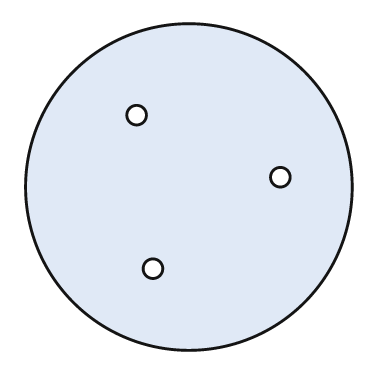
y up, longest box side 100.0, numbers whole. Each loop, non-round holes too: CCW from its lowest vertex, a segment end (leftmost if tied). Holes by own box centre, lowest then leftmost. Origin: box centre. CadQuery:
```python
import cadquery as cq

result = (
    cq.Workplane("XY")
    .moveTo(0.0, 0.0)
    .circle(50.0)
    .moveTo(-11.0, -25.0)
    .circle(3.0)
    .moveTo(28.0, 3.0)
    .circle(3.0)
    .moveTo(-16.0, 22.0)
    .circle(3.0)
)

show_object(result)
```